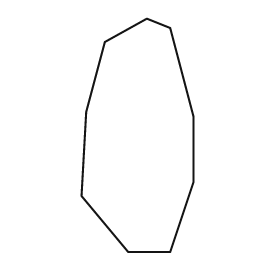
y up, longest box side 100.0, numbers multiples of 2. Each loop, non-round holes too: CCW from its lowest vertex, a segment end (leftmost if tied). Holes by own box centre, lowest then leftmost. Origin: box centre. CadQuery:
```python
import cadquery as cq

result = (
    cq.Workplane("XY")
    .moveTo(-4.0, -50.0)
    .lineTo(14.0, -50.0)
    .lineTo(24.0, -20.0)
    .lineTo(24.0, 8.0)
    .lineTo(14.0, 46.0)
    .lineTo(4.0, 50.0)
    .lineTo(-14.0, 40.0)
    .lineTo(-22.0, 10.0)
    .lineTo(-24.0, -26.0)
    .close()
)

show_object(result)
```